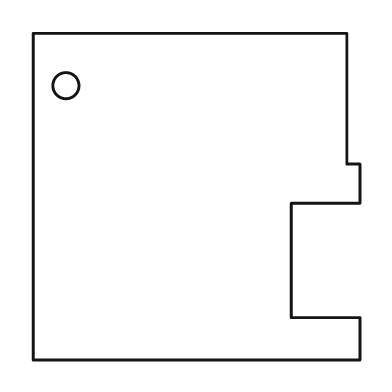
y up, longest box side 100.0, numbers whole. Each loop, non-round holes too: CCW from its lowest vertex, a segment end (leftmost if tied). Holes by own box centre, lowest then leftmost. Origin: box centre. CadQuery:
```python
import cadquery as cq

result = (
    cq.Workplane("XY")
    .moveTo(-50.0, -50.0)
    .lineTo(50.0, -50.0)
    .lineTo(50.0, -37.0)
    .lineTo(29.0, -37.0)
    .lineTo(29.0, -2.0)
    .lineTo(50.0, -2.0)
    .lineTo(50.0, 10.0)
    .lineTo(46.0, 10.0)
    .lineTo(46.0, 50.0)
    .lineTo(-50.0, 50.0)
    .close()
    .moveTo(-40.0, 34.0)
    .circle(4.0)
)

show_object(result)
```